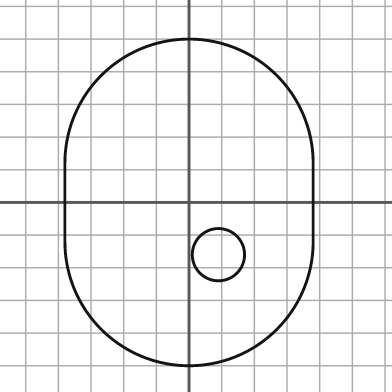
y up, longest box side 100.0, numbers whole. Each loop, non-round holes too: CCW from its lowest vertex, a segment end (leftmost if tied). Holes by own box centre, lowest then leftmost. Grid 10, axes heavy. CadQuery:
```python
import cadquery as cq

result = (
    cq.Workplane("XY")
    .moveTo(-38.0, -12.0)
    .threePointArc((0.0, -50.0), (38.0, -12.0))
    .lineTo(38.0, 12.0)
    .threePointArc((0.0, 50.0), (-38.0, 12.0))
    .close()
    .moveTo(9.0, -16.0)
    .circle(8.0)
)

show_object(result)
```